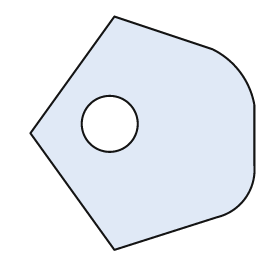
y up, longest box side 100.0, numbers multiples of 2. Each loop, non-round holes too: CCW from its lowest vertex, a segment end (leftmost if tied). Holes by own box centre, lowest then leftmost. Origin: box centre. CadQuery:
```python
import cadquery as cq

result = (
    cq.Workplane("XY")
    .moveTo(-12.0, -50.0)
    .lineTo(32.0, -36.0)
    .threePointArc((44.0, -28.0), (48.0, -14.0))
    .lineTo(48.0, 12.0)
    .threePointArc((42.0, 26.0), (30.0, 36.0))
    .lineTo(-12.0, 50.0)
    .lineTo(-48.0, 0.0)
    .close()
    .moveTo(-14.0, 4.0)
    .circle(12.0)
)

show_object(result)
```